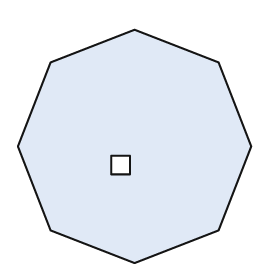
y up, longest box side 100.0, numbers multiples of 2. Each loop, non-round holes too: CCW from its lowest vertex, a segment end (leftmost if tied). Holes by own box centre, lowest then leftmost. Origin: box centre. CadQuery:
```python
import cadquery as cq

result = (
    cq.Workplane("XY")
    .moveTo(0.0, -50.0)
    .lineTo(36.0, -36.0)
    .lineTo(50.0, 0.0)
    .lineTo(36.0, 36.0)
    .lineTo(0.0, 50.0)
    .lineTo(-36.0, 36.0)
    .lineTo(-50.0, 0.0)
    .lineTo(-36.0, -36.0)
    .close()
    .moveTo(-10.0, -12.0)
    .lineTo(-2.0, -12.0)
    .lineTo(-2.0, -4.0)
    .lineTo(-10.0, -4.0)
    .close()
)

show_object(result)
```